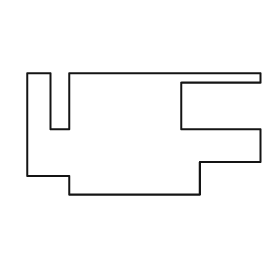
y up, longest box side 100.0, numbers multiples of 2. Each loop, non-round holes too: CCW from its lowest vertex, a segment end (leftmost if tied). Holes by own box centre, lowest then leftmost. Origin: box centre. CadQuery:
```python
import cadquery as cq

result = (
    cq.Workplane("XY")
    .moveTo(-32.0, -26.0)
    .lineTo(24.0, -26.0)
    .lineTo(24.0, -12.0)
    .lineTo(50.0, -12.0)
    .lineTo(50.0, 2.0)
    .lineTo(16.0, 2.0)
    .lineTo(16.0, 22.0)
    .lineTo(50.0, 22.0)
    .lineTo(50.0, 26.0)
    .lineTo(-32.0, 26.0)
    .lineTo(-32.0, 2.0)
    .lineTo(-40.0, 2.0)
    .lineTo(-40.0, 26.0)
    .lineTo(-50.0, 26.0)
    .lineTo(-50.0, -18.0)
    .lineTo(-32.0, -18.0)
    .close()
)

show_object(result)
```